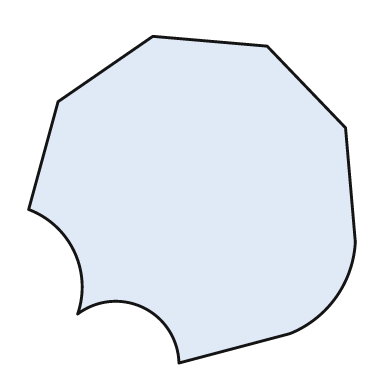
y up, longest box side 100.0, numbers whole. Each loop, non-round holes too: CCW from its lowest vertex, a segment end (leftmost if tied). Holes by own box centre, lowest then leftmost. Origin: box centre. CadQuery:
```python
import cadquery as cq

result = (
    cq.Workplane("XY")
    .moveTo(-4.0, -50.0)
    .lineTo(30.0, -41.0)
    .threePointArc((44.0, -30.0), (50.0, -13.0))
    .lineTo(47.0, 22.0)
    .lineTo(23.0, 47.0)
    .lineTo(-12.0, 50.0)
    .lineTo(-41.0, 30.0)
    .lineTo(-50.0, -3.0)
    .threePointArc((-36.0, -16.0), (-35.0, -35.0))
    .threePointArc((-15.0, -33.0), (-4.0, -50.0))
    .close()
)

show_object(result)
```